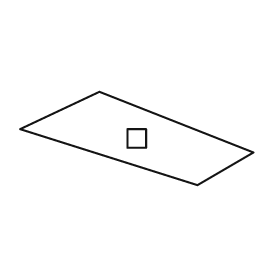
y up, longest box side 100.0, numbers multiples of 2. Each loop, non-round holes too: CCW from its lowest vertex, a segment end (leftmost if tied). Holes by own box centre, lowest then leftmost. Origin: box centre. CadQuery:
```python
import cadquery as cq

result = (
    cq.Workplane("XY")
    .moveTo(26.0, -20.0)
    .lineTo(50.0, -6.0)
    .lineTo(-16.0, 20.0)
    .lineTo(-50.0, 4.0)
    .close()
    .moveTo(-4.0, -4.0)
    .lineTo(4.0, -4.0)
    .lineTo(4.0, 4.0)
    .lineTo(-4.0, 4.0)
    .close()
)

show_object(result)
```